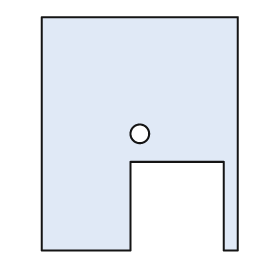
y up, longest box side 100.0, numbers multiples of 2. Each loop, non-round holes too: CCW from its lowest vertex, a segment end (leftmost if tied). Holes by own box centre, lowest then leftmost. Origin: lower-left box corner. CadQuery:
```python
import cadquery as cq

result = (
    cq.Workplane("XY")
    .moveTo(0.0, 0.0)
    .lineTo(38.0, 0.0)
    .lineTo(38.0, 38.0)
    .lineTo(78.0, 38.0)
    .lineTo(78.0, 0.0)
    .lineTo(84.0, 0.0)
    .lineTo(84.0, 100.0)
    .lineTo(0.0, 100.0)
    .close()
    .moveTo(42.0, 50.0)
    .circle(4.0)
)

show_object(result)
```